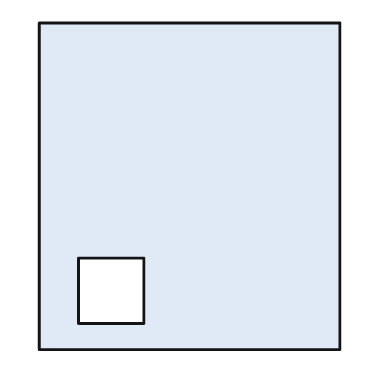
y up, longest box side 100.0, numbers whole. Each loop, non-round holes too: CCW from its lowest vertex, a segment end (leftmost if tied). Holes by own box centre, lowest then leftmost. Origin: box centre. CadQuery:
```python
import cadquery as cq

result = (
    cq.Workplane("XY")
    .moveTo(-46.0, -50.0)
    .lineTo(46.0, -50.0)
    .lineTo(46.0, 50.0)
    .lineTo(-46.0, 50.0)
    .close()
    .moveTo(-34.0, -42.0)
    .lineTo(-14.0, -42.0)
    .lineTo(-14.0, -22.0)
    .lineTo(-34.0, -22.0)
    .close()
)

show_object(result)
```